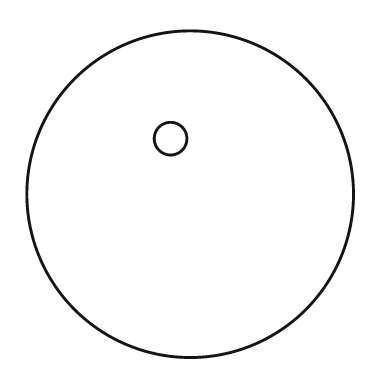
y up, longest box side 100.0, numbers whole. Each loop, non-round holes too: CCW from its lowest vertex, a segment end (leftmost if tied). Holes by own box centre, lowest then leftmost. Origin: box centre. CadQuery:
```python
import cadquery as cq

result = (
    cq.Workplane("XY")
    .moveTo(0.0, 0.0)
    .circle(50.0)
    .moveTo(-6.0, 17.0)
    .circle(5.0)
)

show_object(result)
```